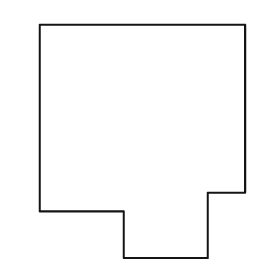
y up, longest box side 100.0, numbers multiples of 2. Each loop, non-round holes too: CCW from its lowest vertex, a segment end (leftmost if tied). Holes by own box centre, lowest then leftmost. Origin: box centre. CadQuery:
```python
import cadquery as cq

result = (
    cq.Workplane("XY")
    .moveTo(-8.0, -50.0)
    .lineTo(28.0, -50.0)
    .lineTo(28.0, -22.0)
    .lineTo(44.0, -22.0)
    .lineTo(44.0, 50.0)
    .lineTo(-44.0, 50.0)
    .lineTo(-44.0, -30.0)
    .lineTo(-8.0, -30.0)
    .close()
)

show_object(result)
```